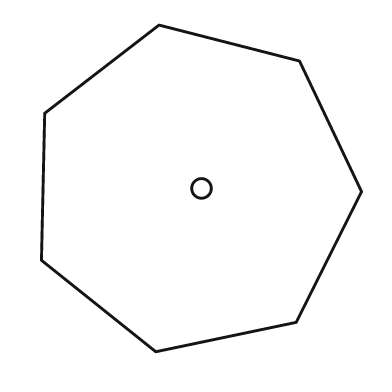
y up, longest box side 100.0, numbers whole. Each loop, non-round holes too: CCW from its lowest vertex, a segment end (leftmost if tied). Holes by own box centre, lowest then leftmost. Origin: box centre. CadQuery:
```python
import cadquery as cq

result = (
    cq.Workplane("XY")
    .moveTo(-14.0, -50.0)
    .lineTo(29.0, -41.0)
    .lineTo(49.0, -1.0)
    .lineTo(30.0, 39.0)
    .lineTo(-13.0, 50.0)
    .lineTo(-48.0, 23.0)
    .lineTo(-49.0, -22.0)
    .close()
    .moveTo(0.0, 0.0)
    .circle(3.0)
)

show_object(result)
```